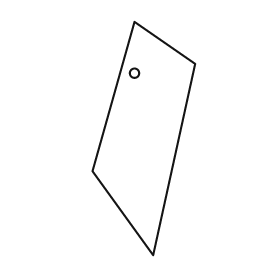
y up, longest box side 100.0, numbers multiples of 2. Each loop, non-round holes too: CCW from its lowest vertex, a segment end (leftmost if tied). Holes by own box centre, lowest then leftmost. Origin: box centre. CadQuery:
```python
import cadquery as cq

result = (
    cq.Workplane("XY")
    .moveTo(4.0, -50.0)
    .lineTo(22.0, 32.0)
    .lineTo(-4.0, 50.0)
    .lineTo(-22.0, -14.0)
    .close()
    .moveTo(-4.0, 28.0)
    .circle(2.0)
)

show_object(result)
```